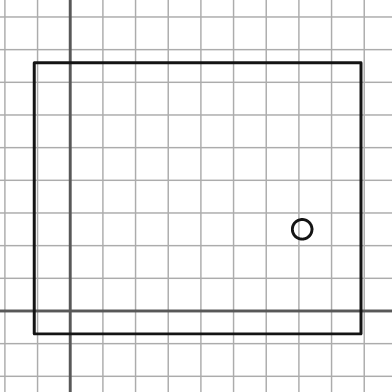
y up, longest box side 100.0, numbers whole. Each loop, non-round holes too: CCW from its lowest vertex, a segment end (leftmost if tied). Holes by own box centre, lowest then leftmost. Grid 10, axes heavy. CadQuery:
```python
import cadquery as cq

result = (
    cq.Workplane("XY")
    .moveTo(-11.0, -7.0)
    .lineTo(89.0, -7.0)
    .lineTo(89.0, 76.0)
    .lineTo(-11.0, 76.0)
    .close()
    .moveTo(71.0, 25.0)
    .circle(3.0)
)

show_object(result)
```